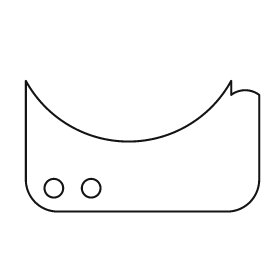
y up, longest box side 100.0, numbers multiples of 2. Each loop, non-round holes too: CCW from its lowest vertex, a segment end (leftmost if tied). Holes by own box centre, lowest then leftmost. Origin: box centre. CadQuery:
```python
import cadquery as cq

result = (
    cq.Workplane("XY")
    .moveTo(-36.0, -28.0)
    .lineTo(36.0, -28.0)
    .threePointArc((46.0, -24.0), (50.0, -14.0))
    .lineTo(50.0, 22.0)
    .threePointArc((44.0, 24.0), (38.0, 22.0))
    .lineTo(38.0, 28.0)
    .threePointArc((-6.0, 2.0), (-50.0, 28.0))
    .lineTo(-50.0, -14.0)
    .threePointArc((-46.0, -24.0), (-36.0, -28.0))
    .close()
    .moveTo(-38.0, -18.0)
    .circle(4.0)
    .moveTo(-22.0, -18.0)
    .circle(4.0)
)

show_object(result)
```